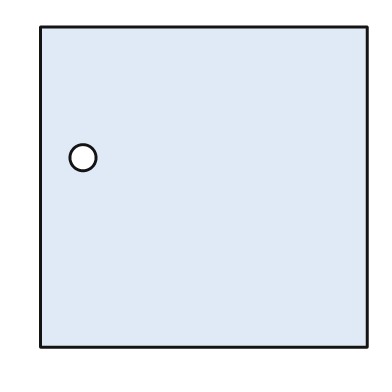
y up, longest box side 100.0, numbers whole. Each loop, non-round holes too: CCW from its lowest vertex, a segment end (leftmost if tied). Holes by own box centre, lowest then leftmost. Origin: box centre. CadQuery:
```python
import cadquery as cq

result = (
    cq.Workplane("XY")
    .moveTo(-50.0, -49.0)
    .lineTo(50.0, -49.0)
    .lineTo(50.0, 49.0)
    .lineTo(-50.0, 49.0)
    .close()
    .moveTo(-37.0, 9.0)
    .circle(4.0)
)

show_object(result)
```